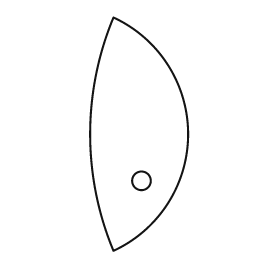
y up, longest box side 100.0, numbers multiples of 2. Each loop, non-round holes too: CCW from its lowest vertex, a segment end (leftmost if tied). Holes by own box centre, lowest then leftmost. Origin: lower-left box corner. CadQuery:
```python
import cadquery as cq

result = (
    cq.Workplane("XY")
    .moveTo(10.0, 0.0)
    .threePointArc((42.0, 50.0), (10.0, 100.0))
    .threePointArc((0.0, 50.0), (10.0, 0.0))
    .close()
    .moveTo(22.0, 30.0)
    .circle(4.0)
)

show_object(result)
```